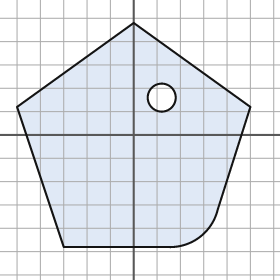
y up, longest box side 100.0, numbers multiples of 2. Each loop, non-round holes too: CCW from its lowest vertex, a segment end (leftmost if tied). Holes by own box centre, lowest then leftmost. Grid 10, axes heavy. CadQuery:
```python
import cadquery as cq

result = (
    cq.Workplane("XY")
    .moveTo(-30.0, -48.0)
    .lineTo(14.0, -48.0)
    .threePointArc((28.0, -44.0), (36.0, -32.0))
    .lineTo(50.0, 12.0)
    .lineTo(0.0, 48.0)
    .lineTo(-50.0, 12.0)
    .close()
    .moveTo(12.0, 16.0)
    .circle(6.0)
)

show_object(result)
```